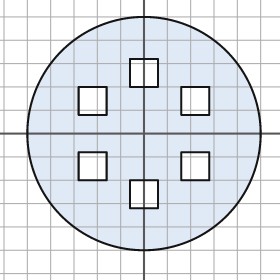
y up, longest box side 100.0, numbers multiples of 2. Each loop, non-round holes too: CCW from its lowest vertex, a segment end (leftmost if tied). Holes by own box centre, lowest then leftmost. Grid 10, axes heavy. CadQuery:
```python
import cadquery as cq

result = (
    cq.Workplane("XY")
    .moveTo(0.0, 0.0)
    .circle(50.0)
    .moveTo(-6.0, -32.0)
    .lineTo(6.0, -32.0)
    .lineTo(6.0, -20.0)
    .lineTo(-6.0, -20.0)
    .close()
    .moveTo(-28.0, -20.0)
    .lineTo(-16.0, -20.0)
    .lineTo(-16.0, -8.0)
    .lineTo(-28.0, -8.0)
    .close()
    .moveTo(16.0, -20.0)
    .lineTo(28.0, -20.0)
    .lineTo(28.0, -8.0)
    .lineTo(16.0, -8.0)
    .close()
    .moveTo(-28.0, 8.0)
    .lineTo(-16.0, 8.0)
    .lineTo(-16.0, 20.0)
    .lineTo(-28.0, 20.0)
    .close()
    .moveTo(16.0, 8.0)
    .lineTo(28.0, 8.0)
    .lineTo(28.0, 20.0)
    .lineTo(16.0, 20.0)
    .close()
    .moveTo(-6.0, 20.0)
    .lineTo(6.0, 20.0)
    .lineTo(6.0, 32.0)
    .lineTo(-6.0, 32.0)
    .close()
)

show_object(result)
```